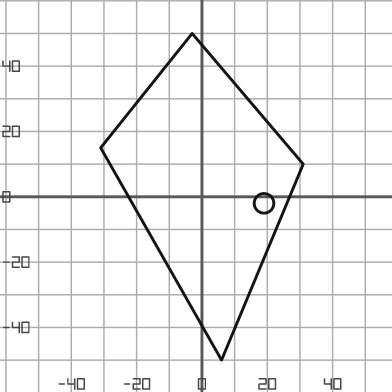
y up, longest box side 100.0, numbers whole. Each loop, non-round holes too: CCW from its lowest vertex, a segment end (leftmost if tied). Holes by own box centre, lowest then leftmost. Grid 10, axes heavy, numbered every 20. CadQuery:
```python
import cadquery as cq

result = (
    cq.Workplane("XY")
    .moveTo(6.0, -50.0)
    .lineTo(31.0, 10.0)
    .lineTo(-3.0, 50.0)
    .lineTo(-31.0, 15.0)
    .close()
    .moveTo(19.0, -2.0)
    .circle(3.0)
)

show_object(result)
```